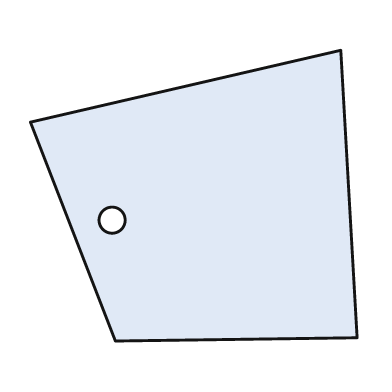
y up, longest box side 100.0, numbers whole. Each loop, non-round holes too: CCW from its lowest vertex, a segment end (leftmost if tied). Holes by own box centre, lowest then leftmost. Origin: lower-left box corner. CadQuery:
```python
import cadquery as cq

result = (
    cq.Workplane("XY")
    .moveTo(26.0, 0.0)
    .lineTo(100.0, 1.0)
    .lineTo(95.0, 89.0)
    .lineTo(0.0, 67.0)
    .close()
    .moveTo(25.0, 37.0)
    .circle(4.0)
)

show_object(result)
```